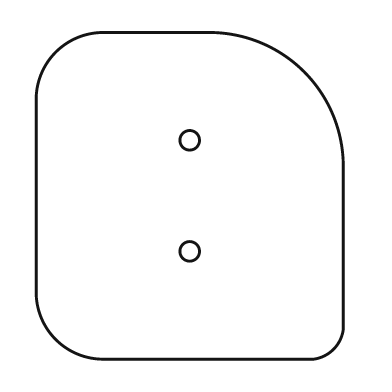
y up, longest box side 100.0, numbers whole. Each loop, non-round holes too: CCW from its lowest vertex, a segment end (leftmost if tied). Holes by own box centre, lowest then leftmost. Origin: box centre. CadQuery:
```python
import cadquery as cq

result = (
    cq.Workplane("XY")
    .moveTo(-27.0, -50.0)
    .lineTo(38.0, -50.0)
    .threePointArc((44.0, -47.0), (47.0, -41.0))
    .lineTo(47.0, 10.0)
    .threePointArc((35.0, 38.0), (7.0, 50.0))
    .lineTo(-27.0, 50.0)
    .threePointArc((-41.0, 44.0), (-47.0, 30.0))
    .lineTo(-47.0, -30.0)
    .threePointArc((-41.0, -44.0), (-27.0, -50.0))
    .close()
    .moveTo(0.0, -17.0)
    .circle(3.0)
    .moveTo(0.0, 17.0)
    .circle(3.0)
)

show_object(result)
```